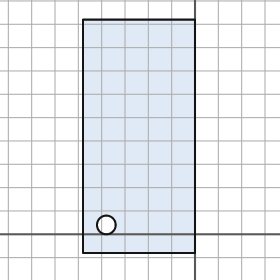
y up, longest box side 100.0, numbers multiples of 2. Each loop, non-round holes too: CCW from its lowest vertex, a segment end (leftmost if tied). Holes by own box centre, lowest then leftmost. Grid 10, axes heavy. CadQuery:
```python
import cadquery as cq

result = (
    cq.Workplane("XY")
    .moveTo(-48.0, -8.0)
    .lineTo(0.0, -8.0)
    .lineTo(0.0, 92.0)
    .lineTo(-48.0, 92.0)
    .close()
    .moveTo(-38.0, 4.0)
    .circle(4.0)
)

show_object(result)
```